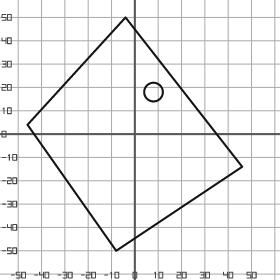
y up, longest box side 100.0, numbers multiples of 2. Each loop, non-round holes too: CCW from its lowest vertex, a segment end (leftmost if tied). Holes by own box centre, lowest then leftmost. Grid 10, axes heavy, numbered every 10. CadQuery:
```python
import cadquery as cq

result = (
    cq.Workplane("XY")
    .moveTo(-8.0, -50.0)
    .lineTo(46.0, -14.0)
    .lineTo(-4.0, 50.0)
    .lineTo(-46.0, 4.0)
    .close()
    .moveTo(8.0, 18.0)
    .circle(4.0)
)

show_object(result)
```